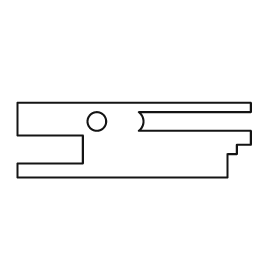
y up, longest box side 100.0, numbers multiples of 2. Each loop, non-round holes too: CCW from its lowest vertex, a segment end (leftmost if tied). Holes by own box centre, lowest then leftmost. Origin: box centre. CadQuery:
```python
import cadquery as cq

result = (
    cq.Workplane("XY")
    .moveTo(-50.0, -16.0)
    .lineTo(40.0, -16.0)
    .lineTo(40.0, -6.0)
    .lineTo(44.0, -6.0)
    .lineTo(44.0, -2.0)
    .lineTo(50.0, -2.0)
    .lineTo(50.0, 4.0)
    .lineTo(2.0, 4.0)
    .threePointArc((4.0, 8.0), (2.0, 12.0))
    .lineTo(50.0, 12.0)
    .lineTo(50.0, 16.0)
    .lineTo(-50.0, 16.0)
    .lineTo(-50.0, 2.0)
    .lineTo(-22.0, 2.0)
    .lineTo(-22.0, -10.0)
    .lineTo(-50.0, -10.0)
    .close()
    .moveTo(-16.0, 8.0)
    .circle(4.0)
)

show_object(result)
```